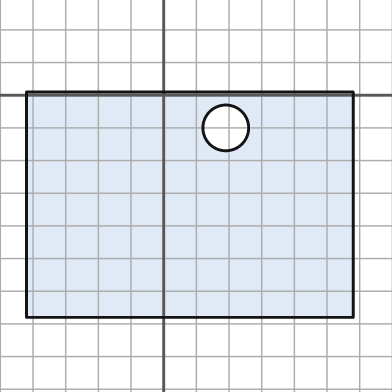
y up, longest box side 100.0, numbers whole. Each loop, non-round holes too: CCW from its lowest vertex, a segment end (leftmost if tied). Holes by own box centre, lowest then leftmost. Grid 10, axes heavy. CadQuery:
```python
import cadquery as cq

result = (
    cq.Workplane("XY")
    .moveTo(-42.0, -68.0)
    .lineTo(58.0, -68.0)
    .lineTo(58.0, 1.0)
    .lineTo(-42.0, 1.0)
    .close()
    .moveTo(19.0, -10.0)
    .circle(7.0)
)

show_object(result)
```